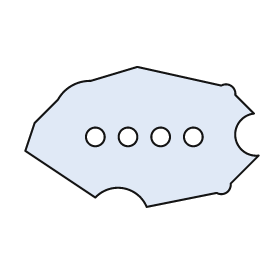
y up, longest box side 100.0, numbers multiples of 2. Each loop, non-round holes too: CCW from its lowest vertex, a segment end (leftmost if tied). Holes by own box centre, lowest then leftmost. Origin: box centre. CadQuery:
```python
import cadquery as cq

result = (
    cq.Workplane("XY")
    .moveTo(2.0, -30.0)
    .lineTo(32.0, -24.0)
    .threePointArc((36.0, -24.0), (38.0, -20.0))
    .lineTo(50.0, -8.0)
    .threePointArc((40.0, 0.0), (48.0, 10.0))
    .lineTo(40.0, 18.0)
    .threePointArc((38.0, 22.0), (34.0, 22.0))
    .lineTo(-2.0, 30.0)
    .lineTo(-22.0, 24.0)
    .threePointArc((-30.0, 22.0), (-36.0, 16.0))
    .lineTo(-46.0, 6.0)
    .lineTo(-50.0, -6.0)
    .lineTo(-20.0, -26.0)
    .threePointArc((-8.0, -22.0), (2.0, -30.0))
    .close()
    .moveTo(-20.0, 0.0)
    .circle(4.0)
    .moveTo(-6.0, 0.0)
    .circle(4.0)
    .moveTo(8.0, 0.0)
    .circle(4.0)
    .moveTo(22.0, 0.0)
    .circle(4.0)
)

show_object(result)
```